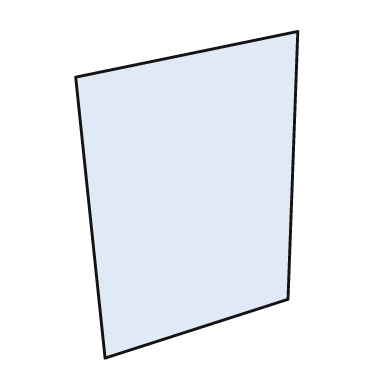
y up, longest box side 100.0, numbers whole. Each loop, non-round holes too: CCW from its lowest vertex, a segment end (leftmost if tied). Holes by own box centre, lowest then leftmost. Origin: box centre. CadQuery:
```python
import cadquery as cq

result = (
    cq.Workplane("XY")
    .moveTo(-25.0, -50.0)
    .lineTo(31.0, -32.0)
    .lineTo(34.0, 50.0)
    .lineTo(-34.0, 36.0)
    .close()
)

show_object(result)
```